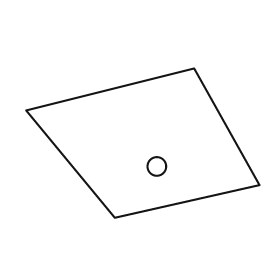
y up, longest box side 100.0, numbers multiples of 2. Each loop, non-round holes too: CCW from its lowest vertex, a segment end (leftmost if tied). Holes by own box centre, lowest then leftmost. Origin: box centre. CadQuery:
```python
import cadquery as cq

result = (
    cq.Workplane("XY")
    .moveTo(-12.0, -32.0)
    .lineTo(50.0, -18.0)
    .lineTo(22.0, 32.0)
    .lineTo(-50.0, 14.0)
    .close()
    .moveTo(6.0, -10.0)
    .circle(4.0)
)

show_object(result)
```